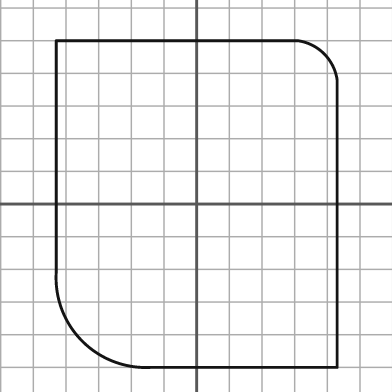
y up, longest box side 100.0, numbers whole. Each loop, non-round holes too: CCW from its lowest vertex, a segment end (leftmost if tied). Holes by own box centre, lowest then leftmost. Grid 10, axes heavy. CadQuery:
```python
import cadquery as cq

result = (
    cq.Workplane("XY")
    .moveTo(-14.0, -50.0)
    .lineTo(43.0, -50.0)
    .lineTo(43.0, 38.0)
    .threePointArc((39.0, 46.0), (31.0, 50.0))
    .lineTo(-43.0, 50.0)
    .lineTo(-43.0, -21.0)
    .threePointArc((-35.0, -42.0), (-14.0, -50.0))
    .close()
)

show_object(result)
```